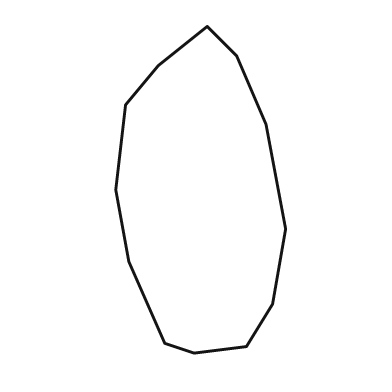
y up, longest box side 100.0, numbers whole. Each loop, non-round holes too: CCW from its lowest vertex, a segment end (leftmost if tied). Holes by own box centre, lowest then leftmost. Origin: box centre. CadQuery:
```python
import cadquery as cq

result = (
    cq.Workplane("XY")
    .moveTo(-2.0, -50.0)
    .lineTo(14.0, -48.0)
    .lineTo(22.0, -35.0)
    .lineTo(26.0, -12.0)
    .lineTo(20.0, 20.0)
    .lineTo(11.0, 41.0)
    .lineTo(2.0, 50.0)
    .lineTo(-13.0, 38.0)
    .lineTo(-23.0, 26.0)
    .lineTo(-26.0, 0.0)
    .lineTo(-22.0, -22.0)
    .lineTo(-11.0, -47.0)
    .close()
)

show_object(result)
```